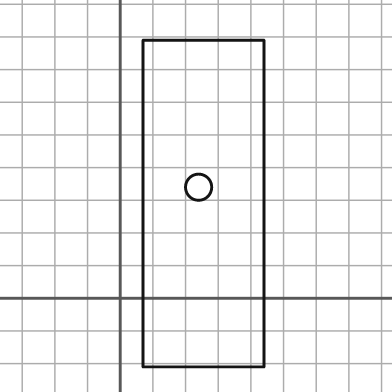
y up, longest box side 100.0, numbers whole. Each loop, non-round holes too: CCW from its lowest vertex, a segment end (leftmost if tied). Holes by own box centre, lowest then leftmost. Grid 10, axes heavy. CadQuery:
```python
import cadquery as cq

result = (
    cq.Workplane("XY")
    .moveTo(7.0, -21.0)
    .lineTo(44.0, -21.0)
    .lineTo(44.0, 79.0)
    .lineTo(7.0, 79.0)
    .close()
    .moveTo(24.0, 34.0)
    .circle(4.0)
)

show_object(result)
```